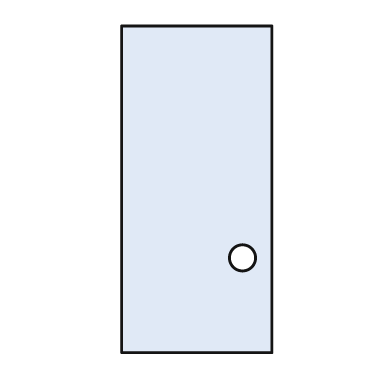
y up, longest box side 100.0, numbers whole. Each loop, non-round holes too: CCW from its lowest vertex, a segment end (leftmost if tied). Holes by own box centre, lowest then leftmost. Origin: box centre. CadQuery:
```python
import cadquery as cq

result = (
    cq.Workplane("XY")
    .moveTo(-23.0, -50.0)
    .lineTo(23.0, -50.0)
    .lineTo(23.0, 50.0)
    .lineTo(-23.0, 50.0)
    .close()
    .moveTo(14.0, -21.0)
    .circle(4.0)
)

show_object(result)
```